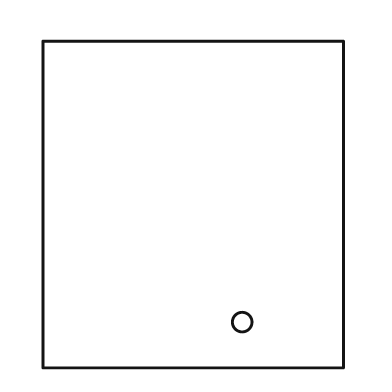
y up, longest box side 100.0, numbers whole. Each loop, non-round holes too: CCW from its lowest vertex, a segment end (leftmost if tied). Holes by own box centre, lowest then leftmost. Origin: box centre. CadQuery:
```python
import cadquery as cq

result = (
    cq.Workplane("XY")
    .moveTo(-46.0, -50.0)
    .lineTo(46.0, -50.0)
    .lineTo(46.0, 50.0)
    .lineTo(-46.0, 50.0)
    .close()
    .moveTo(15.0, -36.0)
    .circle(3.0)
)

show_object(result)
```